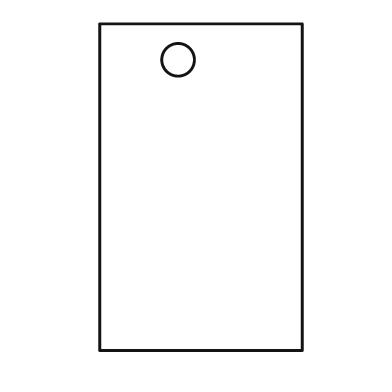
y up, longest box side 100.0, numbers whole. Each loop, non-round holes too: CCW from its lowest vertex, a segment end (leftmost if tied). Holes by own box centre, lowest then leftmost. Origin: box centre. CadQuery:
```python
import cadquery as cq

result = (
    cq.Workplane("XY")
    .moveTo(-31.0, -50.0)
    .lineTo(31.0, -50.0)
    .lineTo(31.0, 50.0)
    .lineTo(-31.0, 50.0)
    .close()
    .moveTo(-7.0, 39.0)
    .circle(5.0)
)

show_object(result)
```